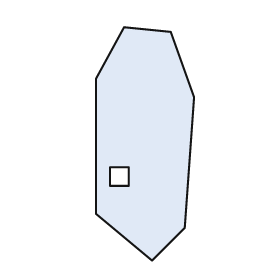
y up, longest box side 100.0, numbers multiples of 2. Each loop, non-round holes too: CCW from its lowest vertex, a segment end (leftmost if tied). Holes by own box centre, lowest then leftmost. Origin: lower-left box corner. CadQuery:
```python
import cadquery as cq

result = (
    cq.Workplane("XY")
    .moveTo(24.0, 0.0)
    .lineTo(38.0, 14.0)
    .lineTo(42.0, 70.0)
    .lineTo(32.0, 98.0)
    .lineTo(12.0, 100.0)
    .lineTo(0.0, 78.0)
    .lineTo(0.0, 20.0)
    .close()
    .moveTo(6.0, 32.0)
    .lineTo(14.0, 32.0)
    .lineTo(14.0, 40.0)
    .lineTo(6.0, 40.0)
    .close()
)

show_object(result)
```